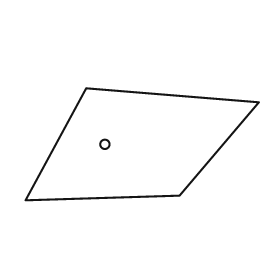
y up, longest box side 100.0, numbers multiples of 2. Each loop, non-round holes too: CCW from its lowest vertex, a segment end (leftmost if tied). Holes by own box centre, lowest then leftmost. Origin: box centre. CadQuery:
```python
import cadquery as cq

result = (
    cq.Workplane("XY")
    .moveTo(-50.0, -24.0)
    .lineTo(16.0, -22.0)
    .lineTo(50.0, 18.0)
    .lineTo(-24.0, 24.0)
    .close()
    .moveTo(-16.0, 0.0)
    .circle(2.0)
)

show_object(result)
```